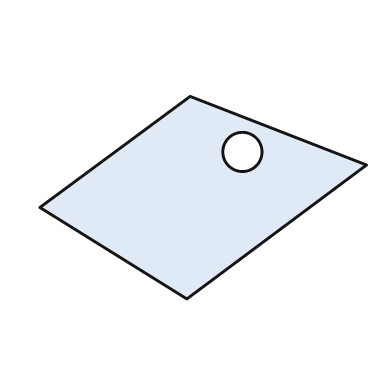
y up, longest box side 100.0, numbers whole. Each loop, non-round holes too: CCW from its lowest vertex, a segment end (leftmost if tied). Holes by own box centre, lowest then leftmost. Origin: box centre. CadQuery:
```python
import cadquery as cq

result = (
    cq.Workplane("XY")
    .moveTo(-5.0, -31.0)
    .lineTo(50.0, 10.0)
    .lineTo(-4.0, 31.0)
    .lineTo(-50.0, -3.0)
    .close()
    .moveTo(12.0, 14.0)
    .circle(6.0)
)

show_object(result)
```